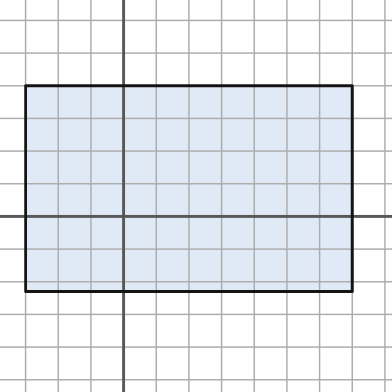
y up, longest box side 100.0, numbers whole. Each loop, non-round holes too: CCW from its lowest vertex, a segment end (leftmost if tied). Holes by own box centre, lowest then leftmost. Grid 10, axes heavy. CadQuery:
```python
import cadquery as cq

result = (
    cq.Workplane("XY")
    .moveTo(-30.0, -23.0)
    .lineTo(70.0, -23.0)
    .lineTo(70.0, 40.0)
    .lineTo(-30.0, 40.0)
    .close()
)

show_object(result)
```